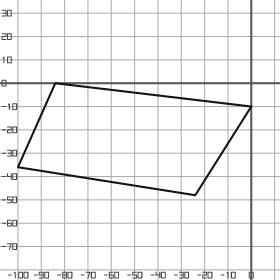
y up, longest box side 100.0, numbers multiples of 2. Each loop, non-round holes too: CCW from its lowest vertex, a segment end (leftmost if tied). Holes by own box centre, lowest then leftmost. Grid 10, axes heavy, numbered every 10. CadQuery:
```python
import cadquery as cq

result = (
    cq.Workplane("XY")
    .moveTo(-24.0, -48.0)
    .lineTo(0.0, -10.0)
    .lineTo(-84.0, 0.0)
    .lineTo(-100.0, -36.0)
    .close()
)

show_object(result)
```